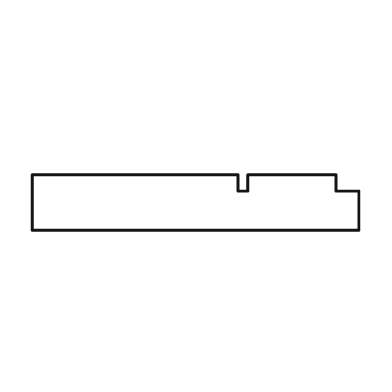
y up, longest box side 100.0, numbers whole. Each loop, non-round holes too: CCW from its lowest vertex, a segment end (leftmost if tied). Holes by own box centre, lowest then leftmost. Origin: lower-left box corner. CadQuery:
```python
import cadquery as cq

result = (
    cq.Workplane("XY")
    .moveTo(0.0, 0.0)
    .lineTo(100.0, 0.0)
    .lineTo(100.0, 12.0)
    .lineTo(93.0, 12.0)
    .lineTo(93.0, 17.0)
    .lineTo(66.0, 17.0)
    .lineTo(66.0, 12.0)
    .lineTo(63.0, 12.0)
    .lineTo(63.0, 17.0)
    .lineTo(0.0, 17.0)
    .close()
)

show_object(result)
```